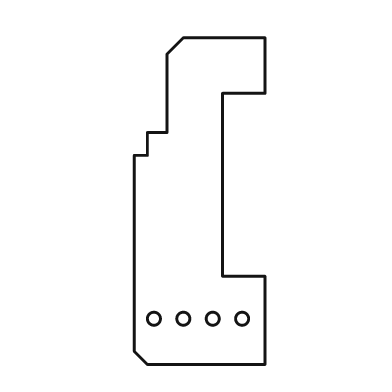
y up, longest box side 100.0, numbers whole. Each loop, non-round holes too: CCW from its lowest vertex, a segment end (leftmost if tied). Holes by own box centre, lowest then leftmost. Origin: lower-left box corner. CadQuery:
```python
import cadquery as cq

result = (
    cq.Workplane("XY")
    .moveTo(4.0, 0.0)
    .lineTo(40.0, 0.0)
    .lineTo(40.0, 27.0)
    .lineTo(27.0, 27.0)
    .lineTo(27.0, 83.0)
    .lineTo(40.0, 83.0)
    .lineTo(40.0, 100.0)
    .lineTo(15.0, 100.0)
    .lineTo(10.0, 95.0)
    .lineTo(10.0, 71.0)
    .lineTo(4.0, 71.0)
    .lineTo(4.0, 64.0)
    .lineTo(0.0, 64.0)
    .lineTo(0.0, 4.0)
    .close()
    .moveTo(6.0, 14.0)
    .circle(2.0)
    .moveTo(15.0, 14.0)
    .circle(2.0)
    .moveTo(24.0, 14.0)
    .circle(2.0)
    .moveTo(33.0, 14.0)
    .circle(2.0)
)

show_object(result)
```